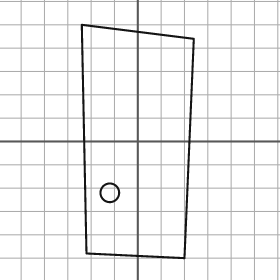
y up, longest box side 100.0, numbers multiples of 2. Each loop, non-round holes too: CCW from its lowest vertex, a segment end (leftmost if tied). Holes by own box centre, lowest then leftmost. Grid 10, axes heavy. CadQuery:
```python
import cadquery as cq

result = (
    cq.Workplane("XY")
    .moveTo(20.0, -50.0)
    .lineTo(24.0, 44.0)
    .lineTo(-24.0, 50.0)
    .lineTo(-22.0, -48.0)
    .close()
    .moveTo(-12.0, -22.0)
    .circle(4.0)
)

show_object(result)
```